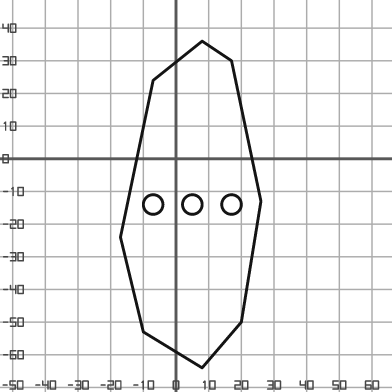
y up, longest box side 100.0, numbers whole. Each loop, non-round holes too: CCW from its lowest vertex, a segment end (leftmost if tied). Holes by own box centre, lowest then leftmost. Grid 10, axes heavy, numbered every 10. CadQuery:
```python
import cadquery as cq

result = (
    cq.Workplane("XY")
    .moveTo(8.0, -64.0)
    .lineTo(20.0, -50.0)
    .lineTo(26.0, -13.0)
    .lineTo(17.0, 30.0)
    .lineTo(8.0, 36.0)
    .lineTo(-7.0, 24.0)
    .lineTo(-17.0, -24.0)
    .lineTo(-10.0, -53.0)
    .close()
    .moveTo(-7.0, -14.0)
    .circle(3.0)
    .moveTo(5.0, -14.0)
    .circle(3.0)
    .moveTo(17.0, -14.0)
    .circle(3.0)
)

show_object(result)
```